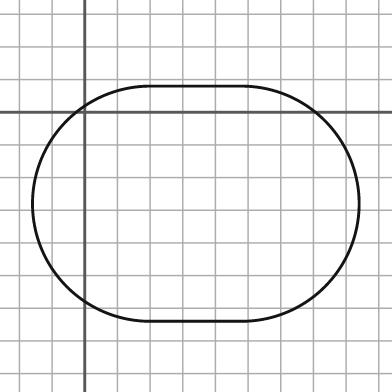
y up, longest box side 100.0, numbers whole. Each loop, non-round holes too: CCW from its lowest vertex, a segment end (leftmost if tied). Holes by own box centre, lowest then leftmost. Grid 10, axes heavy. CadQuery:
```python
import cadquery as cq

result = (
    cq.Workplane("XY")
    .moveTo(20.0, -64.0)
    .lineTo(48.0, -64.0)
    .threePointArc((84.0, -28.0), (48.0, 8.0))
    .lineTo(20.0, 8.0)
    .threePointArc((-16.0, -28.0), (20.0, -64.0))
    .close()
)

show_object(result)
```